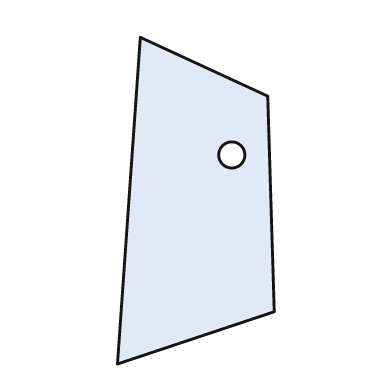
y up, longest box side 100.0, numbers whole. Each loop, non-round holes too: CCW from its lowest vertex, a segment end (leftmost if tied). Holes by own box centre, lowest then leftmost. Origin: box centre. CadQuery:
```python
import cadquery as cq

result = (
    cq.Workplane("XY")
    .moveTo(-24.0, -50.0)
    .lineTo(24.0, -34.0)
    .lineTo(22.0, 32.0)
    .lineTo(-17.0, 50.0)
    .close()
    .moveTo(11.0, 14.0)
    .circle(4.0)
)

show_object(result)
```